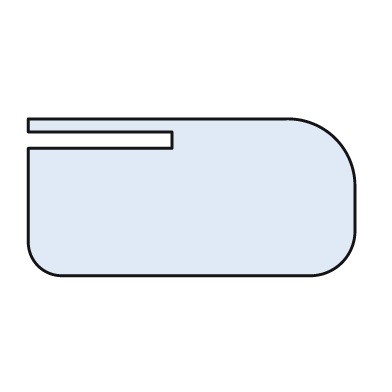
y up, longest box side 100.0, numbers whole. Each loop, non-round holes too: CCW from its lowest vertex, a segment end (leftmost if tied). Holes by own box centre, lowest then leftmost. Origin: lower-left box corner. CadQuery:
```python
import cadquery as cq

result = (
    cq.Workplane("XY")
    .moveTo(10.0, 0.0)
    .lineTo(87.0, 0.0)
    .threePointArc((96.0, 4.0), (100.0, 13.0))
    .lineTo(100.0, 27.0)
    .threePointArc((94.0, 42.0), (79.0, 48.0))
    .lineTo(0.0, 48.0)
    .lineTo(0.0, 44.0)
    .lineTo(44.0, 44.0)
    .lineTo(44.0, 39.0)
    .lineTo(0.0, 39.0)
    .lineTo(0.0, 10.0)
    .threePointArc((3.0, 3.0), (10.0, 0.0))
    .close()
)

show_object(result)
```